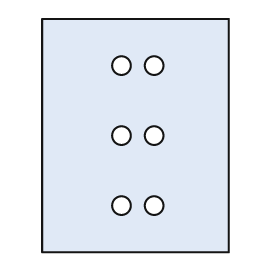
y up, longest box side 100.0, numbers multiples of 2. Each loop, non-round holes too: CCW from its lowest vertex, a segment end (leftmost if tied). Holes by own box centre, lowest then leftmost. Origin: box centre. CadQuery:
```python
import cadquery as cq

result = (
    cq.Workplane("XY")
    .moveTo(-40.0, -50.0)
    .lineTo(40.0, -50.0)
    .lineTo(40.0, 50.0)
    .lineTo(-40.0, 50.0)
    .close()
    .moveTo(-6.0, -30.0)
    .circle(4.0)
    .moveTo(8.0, -30.0)
    .circle(4.0)
    .moveTo(-6.0, 0.0)
    .circle(4.0)
    .moveTo(8.0, 0.0)
    .circle(4.0)
    .moveTo(-6.0, 30.0)
    .circle(4.0)
    .moveTo(8.0, 30.0)
    .circle(4.0)
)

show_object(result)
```